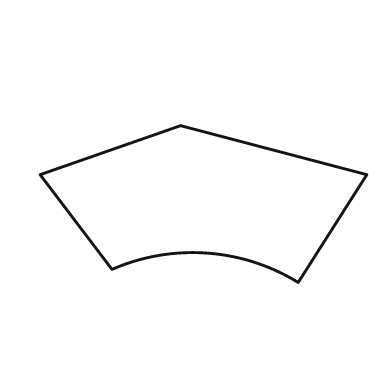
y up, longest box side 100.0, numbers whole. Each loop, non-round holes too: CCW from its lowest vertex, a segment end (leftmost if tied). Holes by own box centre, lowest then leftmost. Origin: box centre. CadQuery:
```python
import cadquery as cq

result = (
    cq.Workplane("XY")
    .moveTo(29.0, -24.0)
    .lineTo(50.0, 9.0)
    .lineTo(-7.0, 24.0)
    .lineTo(-50.0, 9.0)
    .lineTo(-28.0, -20.0)
    .threePointArc((1.0, -15.0), (29.0, -24.0))
    .close()
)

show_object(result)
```